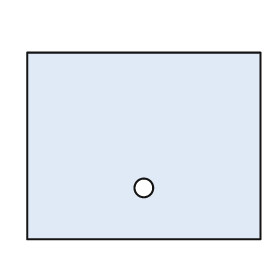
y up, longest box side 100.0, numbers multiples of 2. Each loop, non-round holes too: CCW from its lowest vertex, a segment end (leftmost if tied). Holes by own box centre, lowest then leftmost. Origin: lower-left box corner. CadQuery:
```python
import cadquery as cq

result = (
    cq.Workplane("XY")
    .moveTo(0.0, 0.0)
    .lineTo(100.0, 0.0)
    .lineTo(100.0, 80.0)
    .lineTo(0.0, 80.0)
    .close()
    .moveTo(50.0, 22.0)
    .circle(4.0)
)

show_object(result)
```